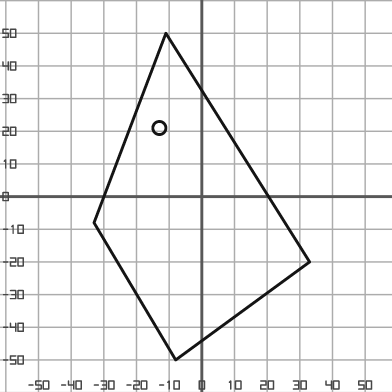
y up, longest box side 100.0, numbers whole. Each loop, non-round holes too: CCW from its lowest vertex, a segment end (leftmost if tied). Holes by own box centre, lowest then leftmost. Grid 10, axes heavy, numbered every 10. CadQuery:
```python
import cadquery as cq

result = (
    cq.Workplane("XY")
    .moveTo(-8.0, -50.0)
    .lineTo(33.0, -20.0)
    .lineTo(-11.0, 50.0)
    .lineTo(-33.0, -8.0)
    .close()
    .moveTo(-13.0, 21.0)
    .circle(2.0)
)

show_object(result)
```